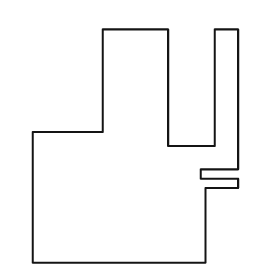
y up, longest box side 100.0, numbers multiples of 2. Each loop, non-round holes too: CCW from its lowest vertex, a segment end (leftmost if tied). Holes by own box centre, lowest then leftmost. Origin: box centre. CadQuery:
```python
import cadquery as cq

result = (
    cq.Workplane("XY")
    .moveTo(-44.0, -50.0)
    .lineTo(30.0, -50.0)
    .lineTo(30.0, -18.0)
    .lineTo(44.0, -18.0)
    .lineTo(44.0, -14.0)
    .lineTo(28.0, -14.0)
    .lineTo(28.0, -10.0)
    .lineTo(44.0, -10.0)
    .lineTo(44.0, 50.0)
    .lineTo(34.0, 50.0)
    .lineTo(34.0, 0.0)
    .lineTo(14.0, 0.0)
    .lineTo(14.0, 50.0)
    .lineTo(-14.0, 50.0)
    .lineTo(-14.0, 6.0)
    .lineTo(-44.0, 6.0)
    .close()
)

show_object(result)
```